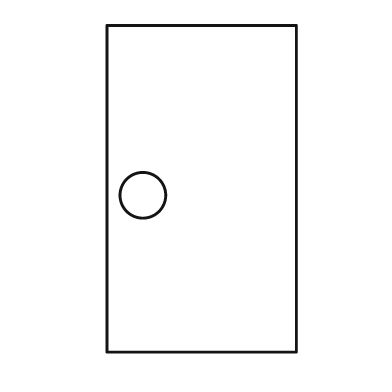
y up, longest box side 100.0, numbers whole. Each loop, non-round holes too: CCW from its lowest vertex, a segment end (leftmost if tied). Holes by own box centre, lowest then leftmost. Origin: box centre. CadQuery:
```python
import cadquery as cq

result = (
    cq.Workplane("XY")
    .moveTo(-29.0, -50.0)
    .lineTo(29.0, -50.0)
    .lineTo(29.0, 50.0)
    .lineTo(-29.0, 50.0)
    .close()
    .moveTo(-18.0, -2.0)
    .circle(7.0)
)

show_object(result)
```